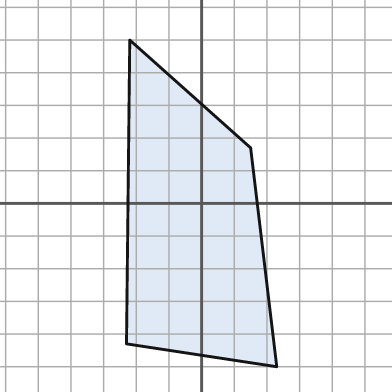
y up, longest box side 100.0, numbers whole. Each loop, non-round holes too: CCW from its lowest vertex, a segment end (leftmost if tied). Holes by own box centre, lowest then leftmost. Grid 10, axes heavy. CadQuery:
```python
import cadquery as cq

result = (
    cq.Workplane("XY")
    .moveTo(23.0, -50.0)
    .lineTo(15.0, 17.0)
    .lineTo(-22.0, 50.0)
    .lineTo(-23.0, -43.0)
    .close()
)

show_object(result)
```